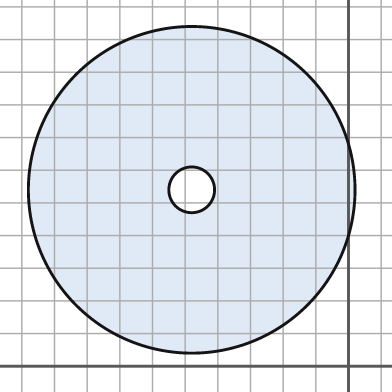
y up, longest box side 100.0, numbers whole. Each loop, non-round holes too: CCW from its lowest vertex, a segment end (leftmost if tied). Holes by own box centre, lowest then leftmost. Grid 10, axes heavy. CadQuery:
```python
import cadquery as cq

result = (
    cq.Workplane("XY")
    .moveTo(-48.0, 54.0)
    .circle(50.0)
    .moveTo(-48.0, 54.0)
    .circle(7.0)
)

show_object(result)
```